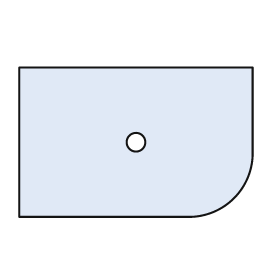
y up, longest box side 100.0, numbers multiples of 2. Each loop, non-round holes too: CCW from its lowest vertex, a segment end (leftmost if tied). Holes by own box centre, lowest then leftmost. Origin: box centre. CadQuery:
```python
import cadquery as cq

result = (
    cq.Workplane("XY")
    .moveTo(-50.0, -32.0)
    .lineTo(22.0, -32.0)
    .threePointArc((42.0, -24.0), (50.0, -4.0))
    .lineTo(50.0, 32.0)
    .lineTo(-50.0, 32.0)
    .close()
    .moveTo(0.0, 0.0)
    .circle(4.0)
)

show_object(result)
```